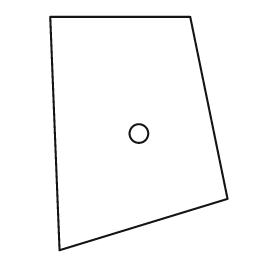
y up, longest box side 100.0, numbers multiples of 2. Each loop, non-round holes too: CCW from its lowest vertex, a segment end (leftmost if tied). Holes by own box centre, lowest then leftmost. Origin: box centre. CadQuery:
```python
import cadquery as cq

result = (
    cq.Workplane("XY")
    .moveTo(-34.0, -50.0)
    .lineTo(38.0, -28.0)
    .lineTo(22.0, 50.0)
    .lineTo(-38.0, 50.0)
    .close()
    .moveTo(0.0, 0.0)
    .circle(4.0)
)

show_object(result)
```